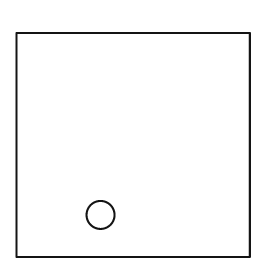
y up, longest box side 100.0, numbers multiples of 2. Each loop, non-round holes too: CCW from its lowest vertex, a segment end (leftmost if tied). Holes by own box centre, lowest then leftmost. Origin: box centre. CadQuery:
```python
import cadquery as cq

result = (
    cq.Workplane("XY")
    .moveTo(-50.0, -48.0)
    .lineTo(50.0, -48.0)
    .lineTo(50.0, 48.0)
    .lineTo(-50.0, 48.0)
    .close()
    .moveTo(-14.0, -30.0)
    .circle(6.0)
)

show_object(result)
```